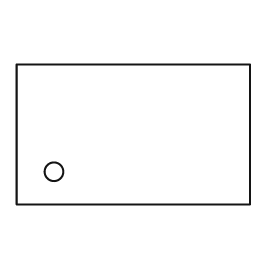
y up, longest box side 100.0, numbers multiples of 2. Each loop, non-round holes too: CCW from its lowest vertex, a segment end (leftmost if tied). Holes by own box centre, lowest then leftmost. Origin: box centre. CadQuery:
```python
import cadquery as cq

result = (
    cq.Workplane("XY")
    .moveTo(-50.0, -30.0)
    .lineTo(50.0, -30.0)
    .lineTo(50.0, 30.0)
    .lineTo(-50.0, 30.0)
    .close()
    .moveTo(-34.0, -16.0)
    .circle(4.0)
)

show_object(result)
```